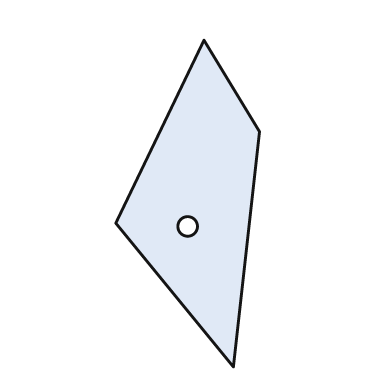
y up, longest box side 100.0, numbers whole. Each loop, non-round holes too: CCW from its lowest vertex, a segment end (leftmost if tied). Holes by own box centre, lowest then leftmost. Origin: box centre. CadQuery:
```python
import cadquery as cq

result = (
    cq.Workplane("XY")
    .moveTo(14.0, -50.0)
    .lineTo(22.0, 22.0)
    .lineTo(5.0, 50.0)
    .lineTo(-22.0, -6.0)
    .close()
    .moveTo(0.0, -7.0)
    .circle(3.0)
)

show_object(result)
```